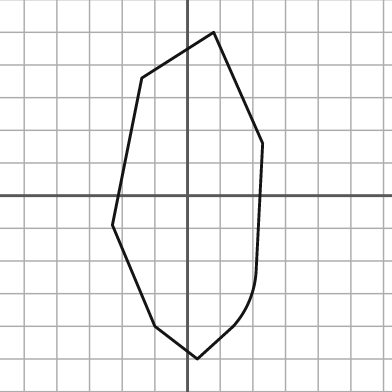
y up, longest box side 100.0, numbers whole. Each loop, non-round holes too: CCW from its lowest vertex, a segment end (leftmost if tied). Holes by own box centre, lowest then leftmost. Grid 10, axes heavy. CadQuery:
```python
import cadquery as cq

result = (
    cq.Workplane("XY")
    .moveTo(3.0, -50.0)
    .lineTo(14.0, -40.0)
    .threePointArc((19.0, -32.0), (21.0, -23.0))
    .lineTo(23.0, 16.0)
    .lineTo(8.0, 50.0)
    .lineTo(-14.0, 36.0)
    .lineTo(-23.0, -9.0)
    .lineTo(-10.0, -40.0)
    .close()
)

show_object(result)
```